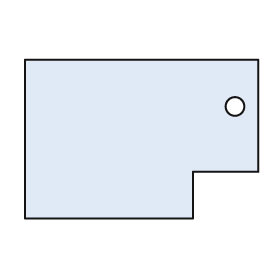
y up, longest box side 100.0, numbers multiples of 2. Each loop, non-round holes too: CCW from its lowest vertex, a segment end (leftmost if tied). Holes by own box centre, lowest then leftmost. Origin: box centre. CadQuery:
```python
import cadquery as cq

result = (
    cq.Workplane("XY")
    .moveTo(-50.0, -34.0)
    .lineTo(22.0, -34.0)
    .lineTo(22.0, -14.0)
    .lineTo(50.0, -14.0)
    .lineTo(50.0, 34.0)
    .lineTo(-50.0, 34.0)
    .close()
    .moveTo(40.0, 14.0)
    .circle(4.0)
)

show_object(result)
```